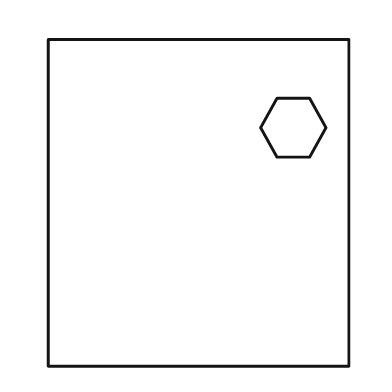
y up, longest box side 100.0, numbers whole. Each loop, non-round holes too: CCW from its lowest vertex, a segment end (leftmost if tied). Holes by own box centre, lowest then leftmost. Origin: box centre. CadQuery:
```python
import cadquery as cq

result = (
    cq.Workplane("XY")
    .moveTo(-46.0, -50.0)
    .lineTo(46.0, -50.0)
    .lineTo(46.0, 50.0)
    .lineTo(-46.0, 50.0)
    .close()
    .moveTo(24.0, 14.0)
    .lineTo(34.0, 14.0)
    .lineTo(39.0, 23.0)
    .lineTo(34.0, 32.0)
    .lineTo(24.0, 32.0)
    .lineTo(19.0, 23.0)
    .close()
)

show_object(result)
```